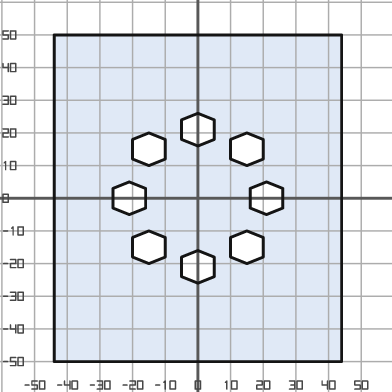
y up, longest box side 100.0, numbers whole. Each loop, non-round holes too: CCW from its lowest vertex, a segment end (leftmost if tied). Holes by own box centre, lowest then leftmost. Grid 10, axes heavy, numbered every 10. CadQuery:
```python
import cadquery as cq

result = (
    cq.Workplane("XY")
    .moveTo(-44.0, -50.0)
    .lineTo(44.0, -50.0)
    .lineTo(44.0, 50.0)
    .lineTo(-44.0, 50.0)
    .close()
    .moveTo(0.0, -26.0)
    .lineTo(5.0, -24.0)
    .lineTo(5.0, -18.0)
    .lineTo(0.0, -16.0)
    .lineTo(-5.0, -18.0)
    .lineTo(-5.0, -24.0)
    .close()
    .moveTo(-15.0, -20.0)
    .lineTo(-10.0, -18.0)
    .lineTo(-10.0, -12.0)
    .lineTo(-15.0, -10.0)
    .lineTo(-20.0, -12.0)
    .lineTo(-20.0, -18.0)
    .close()
    .moveTo(15.0, -20.0)
    .lineTo(20.0, -18.0)
    .lineTo(20.0, -12.0)
    .lineTo(15.0, -10.0)
    .lineTo(10.0, -12.0)
    .lineTo(10.0, -18.0)
    .close()
    .moveTo(-21.0, -5.0)
    .lineTo(-16.0, -3.0)
    .lineTo(-16.0, 3.0)
    .lineTo(-21.0, 5.0)
    .lineTo(-26.0, 3.0)
    .lineTo(-26.0, -3.0)
    .close()
    .moveTo(21.0, -5.0)
    .lineTo(26.0, -3.0)
    .lineTo(26.0, 3.0)
    .lineTo(21.0, 5.0)
    .lineTo(16.0, 3.0)
    .lineTo(16.0, -3.0)
    .close()
    .moveTo(-15.0, 10.0)
    .lineTo(-10.0, 12.0)
    .lineTo(-10.0, 18.0)
    .lineTo(-15.0, 20.0)
    .lineTo(-20.0, 18.0)
    .lineTo(-20.0, 12.0)
    .close()
    .moveTo(15.0, 10.0)
    .lineTo(20.0, 12.0)
    .lineTo(20.0, 18.0)
    .lineTo(15.0, 20.0)
    .lineTo(10.0, 18.0)
    .lineTo(10.0, 12.0)
    .close()
    .moveTo(0.0, 16.0)
    .lineTo(5.0, 18.0)
    .lineTo(5.0, 24.0)
    .lineTo(0.0, 26.0)
    .lineTo(-5.0, 24.0)
    .lineTo(-5.0, 18.0)
    .close()
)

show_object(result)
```